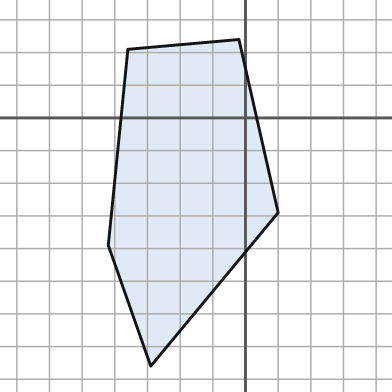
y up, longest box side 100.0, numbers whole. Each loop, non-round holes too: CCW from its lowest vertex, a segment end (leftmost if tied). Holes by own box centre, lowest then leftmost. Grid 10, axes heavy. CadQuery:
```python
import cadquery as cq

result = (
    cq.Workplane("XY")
    .moveTo(-29.0, -76.0)
    .lineTo(10.0, -29.0)
    .lineTo(-2.0, 24.0)
    .lineTo(-36.0, 21.0)
    .lineTo(-42.0, -39.0)
    .close()
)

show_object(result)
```